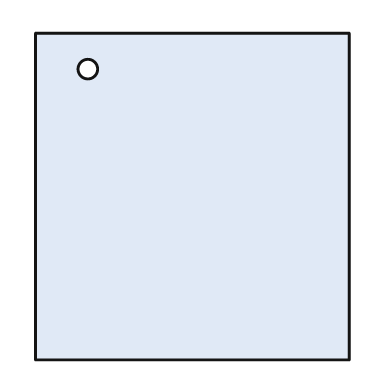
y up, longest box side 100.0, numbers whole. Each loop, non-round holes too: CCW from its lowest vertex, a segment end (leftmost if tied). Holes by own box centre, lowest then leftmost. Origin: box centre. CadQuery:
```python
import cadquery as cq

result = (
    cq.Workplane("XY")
    .moveTo(-48.0, -50.0)
    .lineTo(48.0, -50.0)
    .lineTo(48.0, 50.0)
    .lineTo(-48.0, 50.0)
    .close()
    .moveTo(-32.0, 39.0)
    .circle(3.0)
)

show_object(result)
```